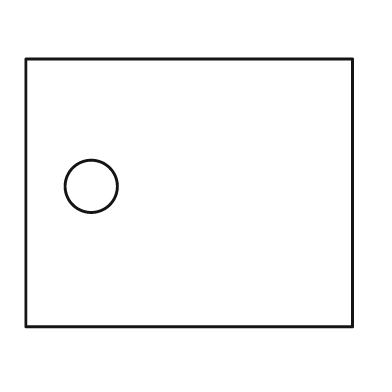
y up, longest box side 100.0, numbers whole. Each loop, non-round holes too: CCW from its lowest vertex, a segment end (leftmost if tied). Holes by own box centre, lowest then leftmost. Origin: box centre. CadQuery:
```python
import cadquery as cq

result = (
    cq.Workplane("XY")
    .moveTo(-50.0, -41.0)
    .lineTo(50.0, -41.0)
    .lineTo(50.0, 41.0)
    .lineTo(-50.0, 41.0)
    .close()
    .moveTo(-30.0, 2.0)
    .circle(8.0)
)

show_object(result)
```